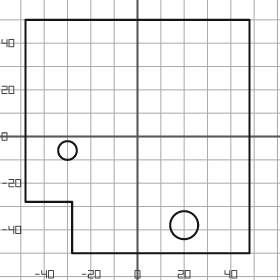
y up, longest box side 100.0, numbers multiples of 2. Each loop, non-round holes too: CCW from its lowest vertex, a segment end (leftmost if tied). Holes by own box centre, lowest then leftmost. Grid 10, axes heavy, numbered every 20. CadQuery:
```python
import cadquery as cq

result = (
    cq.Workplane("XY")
    .moveTo(-28.0, -50.0)
    .lineTo(48.0, -50.0)
    .lineTo(48.0, 50.0)
    .lineTo(-48.0, 50.0)
    .lineTo(-48.0, -28.0)
    .lineTo(-28.0, -28.0)
    .close()
    .moveTo(20.0, -38.0)
    .circle(6.0)
    .moveTo(-30.0, -6.0)
    .circle(4.0)
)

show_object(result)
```